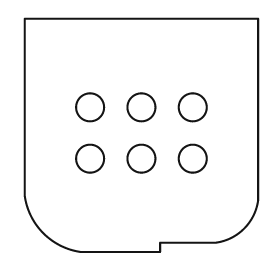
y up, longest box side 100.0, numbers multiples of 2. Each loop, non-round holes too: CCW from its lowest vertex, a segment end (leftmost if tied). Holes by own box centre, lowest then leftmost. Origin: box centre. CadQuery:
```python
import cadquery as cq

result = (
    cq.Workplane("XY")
    .moveTo(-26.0, -50.0)
    .lineTo(8.0, -50.0)
    .lineTo(8.0, -46.0)
    .lineTo(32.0, -46.0)
    .threePointArc((44.0, -40.0), (50.0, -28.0))
    .lineTo(50.0, 50.0)
    .lineTo(-50.0, 50.0)
    .lineTo(-50.0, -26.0)
    .threePointArc((-42.0, -42.0), (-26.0, -50.0))
    .close()
    .moveTo(-22.0, -10.0)
    .circle(6.0)
    .moveTo(0.0, -10.0)
    .circle(6.0)
    .moveTo(22.0, -10.0)
    .circle(6.0)
    .moveTo(-22.0, 12.0)
    .circle(6.0)
    .moveTo(0.0, 12.0)
    .circle(6.0)
    .moveTo(22.0, 12.0)
    .circle(6.0)
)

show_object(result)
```